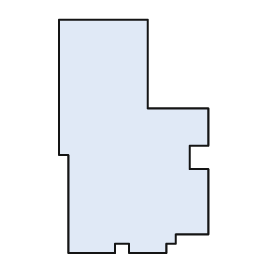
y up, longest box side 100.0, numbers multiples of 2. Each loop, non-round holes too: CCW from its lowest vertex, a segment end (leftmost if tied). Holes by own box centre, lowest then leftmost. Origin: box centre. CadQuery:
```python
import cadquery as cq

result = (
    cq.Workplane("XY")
    .moveTo(-28.0, -50.0)
    .lineTo(-8.0, -50.0)
    .lineTo(-8.0, -46.0)
    .lineTo(-2.0, -46.0)
    .lineTo(-2.0, -50.0)
    .lineTo(14.0, -50.0)
    .lineTo(14.0, -46.0)
    .lineTo(18.0, -46.0)
    .lineTo(18.0, -42.0)
    .lineTo(32.0, -42.0)
    .lineTo(32.0, -14.0)
    .lineTo(24.0, -14.0)
    .lineTo(24.0, -4.0)
    .lineTo(32.0, -4.0)
    .lineTo(32.0, 12.0)
    .lineTo(6.0, 12.0)
    .lineTo(6.0, 50.0)
    .lineTo(-32.0, 50.0)
    .lineTo(-32.0, -8.0)
    .lineTo(-28.0, -8.0)
    .close()
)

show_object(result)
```